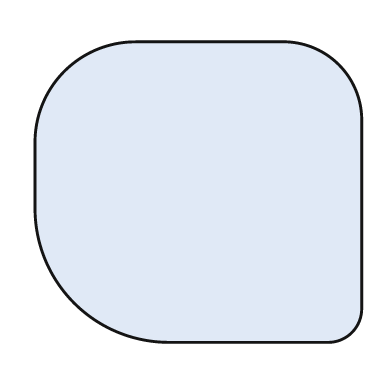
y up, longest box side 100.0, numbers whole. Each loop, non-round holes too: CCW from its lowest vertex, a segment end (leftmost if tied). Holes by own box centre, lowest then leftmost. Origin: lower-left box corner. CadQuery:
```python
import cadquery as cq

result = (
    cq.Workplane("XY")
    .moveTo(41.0, 0.0)
    .lineTo(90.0, 0.0)
    .threePointArc((97.0, 3.0), (100.0, 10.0))
    .lineTo(100.0, 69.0)
    .threePointArc((93.0, 85.0), (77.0, 92.0))
    .lineTo(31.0, 92.0)
    .threePointArc((9.0, 83.0), (0.0, 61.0))
    .lineTo(0.0, 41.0)
    .threePointArc((12.0, 12.0), (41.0, 0.0))
    .close()
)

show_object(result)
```